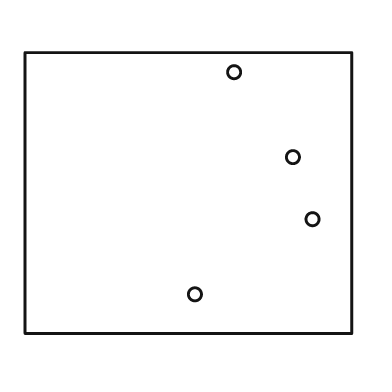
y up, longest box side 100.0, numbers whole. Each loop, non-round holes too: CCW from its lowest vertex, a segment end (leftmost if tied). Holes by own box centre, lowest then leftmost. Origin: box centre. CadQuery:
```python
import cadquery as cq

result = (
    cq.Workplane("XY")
    .moveTo(-50.0, -43.0)
    .lineTo(50.0, -43.0)
    .lineTo(50.0, 43.0)
    .lineTo(-50.0, 43.0)
    .close()
    .moveTo(2.0, -31.0)
    .circle(2.0)
    .moveTo(38.0, -8.0)
    .circle(2.0)
    .moveTo(32.0, 11.0)
    .circle(2.0)
    .moveTo(14.0, 37.0)
    .circle(2.0)
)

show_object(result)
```